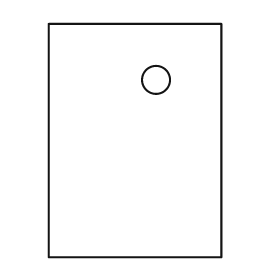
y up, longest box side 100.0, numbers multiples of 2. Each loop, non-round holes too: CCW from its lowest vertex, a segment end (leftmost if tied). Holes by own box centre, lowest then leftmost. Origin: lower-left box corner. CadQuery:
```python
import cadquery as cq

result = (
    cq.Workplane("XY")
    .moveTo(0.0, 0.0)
    .lineTo(74.0, 0.0)
    .lineTo(74.0, 100.0)
    .lineTo(0.0, 100.0)
    .close()
    .moveTo(46.0, 76.0)
    .circle(6.0)
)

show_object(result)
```